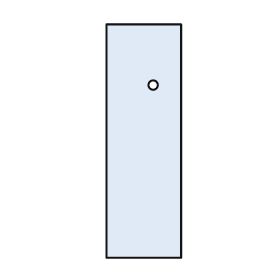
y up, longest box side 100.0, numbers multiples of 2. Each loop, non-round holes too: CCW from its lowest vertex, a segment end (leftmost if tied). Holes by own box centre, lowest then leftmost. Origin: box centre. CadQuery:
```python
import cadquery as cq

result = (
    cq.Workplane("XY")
    .moveTo(-16.0, -50.0)
    .lineTo(16.0, -50.0)
    .lineTo(16.0, 50.0)
    .lineTo(-16.0, 50.0)
    .close()
    .moveTo(4.0, 24.0)
    .circle(2.0)
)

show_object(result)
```